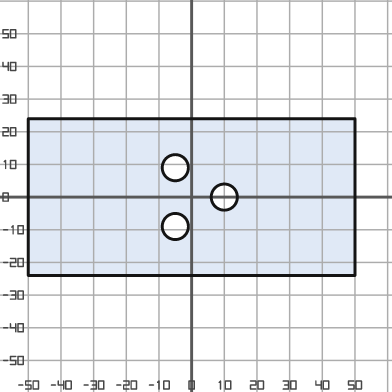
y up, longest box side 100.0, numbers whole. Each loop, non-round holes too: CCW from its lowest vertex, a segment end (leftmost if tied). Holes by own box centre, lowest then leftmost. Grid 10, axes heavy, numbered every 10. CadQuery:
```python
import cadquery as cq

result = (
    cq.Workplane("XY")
    .moveTo(-50.0, -24.0)
    .lineTo(50.0, -24.0)
    .lineTo(50.0, 24.0)
    .lineTo(-50.0, 24.0)
    .close()
    .moveTo(-5.0, -9.0)
    .circle(4.0)
    .moveTo(10.0, 0.0)
    .circle(4.0)
    .moveTo(-5.0, 9.0)
    .circle(4.0)
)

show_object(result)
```